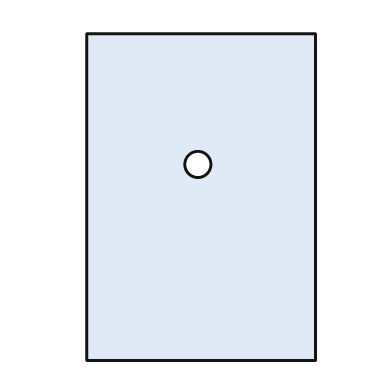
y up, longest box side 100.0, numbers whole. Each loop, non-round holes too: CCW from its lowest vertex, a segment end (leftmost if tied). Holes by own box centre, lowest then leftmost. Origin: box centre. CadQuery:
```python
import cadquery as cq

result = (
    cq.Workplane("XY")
    .moveTo(-35.0, -50.0)
    .lineTo(35.0, -50.0)
    .lineTo(35.0, 50.0)
    .lineTo(-35.0, 50.0)
    .close()
    .moveTo(-1.0, 10.0)
    .circle(4.0)
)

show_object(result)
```